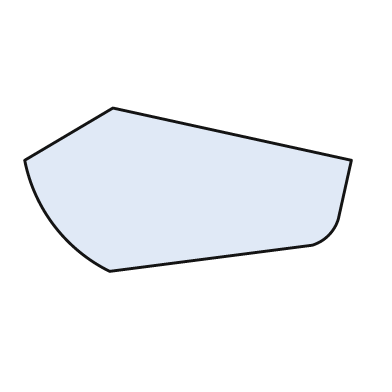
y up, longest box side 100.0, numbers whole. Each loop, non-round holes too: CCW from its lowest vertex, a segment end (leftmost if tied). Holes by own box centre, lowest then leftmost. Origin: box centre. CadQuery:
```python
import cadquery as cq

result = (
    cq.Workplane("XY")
    .moveTo(-24.0, -25.0)
    .lineTo(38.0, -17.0)
    .threePointArc((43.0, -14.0), (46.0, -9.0))
    .lineTo(50.0, 9.0)
    .lineTo(-23.0, 25.0)
    .lineTo(-50.0, 9.0)
    .threePointArc((-41.0, -11.0), (-24.0, -25.0))
    .close()
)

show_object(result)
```